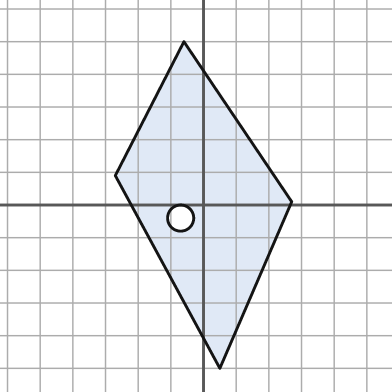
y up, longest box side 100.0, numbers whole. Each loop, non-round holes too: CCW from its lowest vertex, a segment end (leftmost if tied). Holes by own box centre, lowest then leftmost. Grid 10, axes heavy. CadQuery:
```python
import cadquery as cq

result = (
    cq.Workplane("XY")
    .moveTo(5.0, -50.0)
    .lineTo(27.0, 1.0)
    .lineTo(-6.0, 50.0)
    .lineTo(-27.0, 9.0)
    .close()
    .moveTo(-7.0, -4.0)
    .circle(4.0)
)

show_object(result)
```